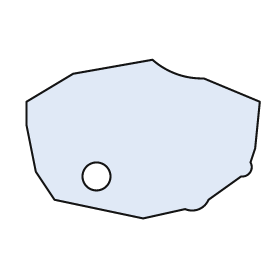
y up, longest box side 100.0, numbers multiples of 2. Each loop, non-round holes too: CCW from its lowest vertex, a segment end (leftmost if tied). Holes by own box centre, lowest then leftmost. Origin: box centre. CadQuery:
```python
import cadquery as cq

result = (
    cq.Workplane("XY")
    .moveTo(0.0, -34.0)
    .lineTo(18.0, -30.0)
    .threePointArc((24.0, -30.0), (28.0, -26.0))
    .lineTo(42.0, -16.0)
    .threePointArc((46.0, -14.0), (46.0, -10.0))
    .lineTo(48.0, -4.0)
    .lineTo(50.0, 16.0)
    .lineTo(26.0, 26.0)
    .threePointArc((14.0, 28.0), (4.0, 34.0))
    .lineTo(-30.0, 28.0)
    .lineTo(-50.0, 16.0)
    .lineTo(-50.0, 6.0)
    .lineTo(-46.0, -14.0)
    .lineTo(-38.0, -26.0)
    .close()
    .moveTo(-20.0, -16.0)
    .circle(6.0)
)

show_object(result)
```